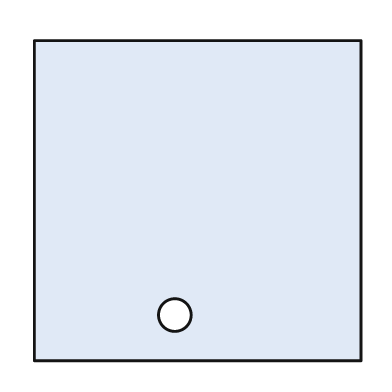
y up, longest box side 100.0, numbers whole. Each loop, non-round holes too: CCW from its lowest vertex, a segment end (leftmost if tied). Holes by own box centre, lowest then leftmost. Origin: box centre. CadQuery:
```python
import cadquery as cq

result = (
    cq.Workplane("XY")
    .moveTo(-50.0, -49.0)
    .lineTo(50.0, -49.0)
    .lineTo(50.0, 49.0)
    .lineTo(-50.0, 49.0)
    .close()
    .moveTo(-7.0, -35.0)
    .circle(5.0)
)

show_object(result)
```